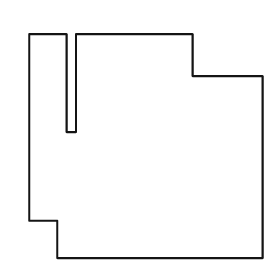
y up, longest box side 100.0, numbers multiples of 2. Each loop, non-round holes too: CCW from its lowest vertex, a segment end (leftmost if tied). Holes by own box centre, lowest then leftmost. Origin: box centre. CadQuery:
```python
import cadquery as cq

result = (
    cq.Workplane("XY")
    .moveTo(-38.0, -48.0)
    .lineTo(50.0, -48.0)
    .lineTo(50.0, 30.0)
    .lineTo(20.0, 30.0)
    .lineTo(20.0, 48.0)
    .lineTo(-30.0, 48.0)
    .lineTo(-30.0, 6.0)
    .lineTo(-34.0, 6.0)
    .lineTo(-34.0, 48.0)
    .lineTo(-50.0, 48.0)
    .lineTo(-50.0, -32.0)
    .lineTo(-38.0, -32.0)
    .close()
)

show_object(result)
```